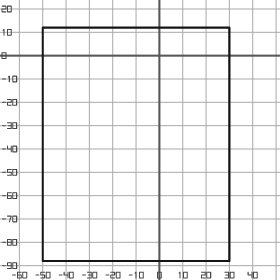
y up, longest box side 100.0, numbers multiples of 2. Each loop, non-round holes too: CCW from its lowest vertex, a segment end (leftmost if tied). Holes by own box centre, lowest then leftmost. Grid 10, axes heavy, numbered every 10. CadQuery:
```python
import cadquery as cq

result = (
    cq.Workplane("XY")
    .moveTo(-50.0, -88.0)
    .lineTo(30.0, -88.0)
    .lineTo(30.0, 12.0)
    .lineTo(-50.0, 12.0)
    .close()
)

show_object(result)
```